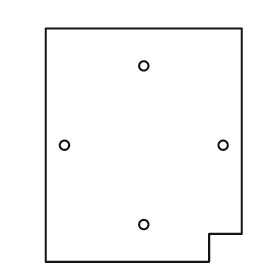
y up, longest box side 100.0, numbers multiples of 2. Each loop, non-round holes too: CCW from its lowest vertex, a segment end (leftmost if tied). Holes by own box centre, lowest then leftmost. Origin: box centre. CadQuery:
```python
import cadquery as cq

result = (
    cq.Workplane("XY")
    .moveTo(-42.0, -50.0)
    .lineTo(28.0, -50.0)
    .lineTo(28.0, -38.0)
    .lineTo(42.0, -38.0)
    .lineTo(42.0, 50.0)
    .lineTo(-42.0, 50.0)
    .close()
    .moveTo(0.0, -34.0)
    .circle(2.0)
    .moveTo(-34.0, 0.0)
    .circle(2.0)
    .moveTo(34.0, 0.0)
    .circle(2.0)
    .moveTo(0.0, 34.0)
    .circle(2.0)
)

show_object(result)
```